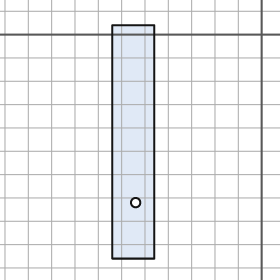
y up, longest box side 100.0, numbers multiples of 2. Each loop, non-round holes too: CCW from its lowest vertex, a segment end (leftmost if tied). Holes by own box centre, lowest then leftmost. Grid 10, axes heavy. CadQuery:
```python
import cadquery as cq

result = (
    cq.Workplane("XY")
    .moveTo(-64.0, -96.0)
    .lineTo(-46.0, -96.0)
    .lineTo(-46.0, 4.0)
    .lineTo(-64.0, 4.0)
    .close()
    .moveTo(-54.0, -72.0)
    .circle(2.0)
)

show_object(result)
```